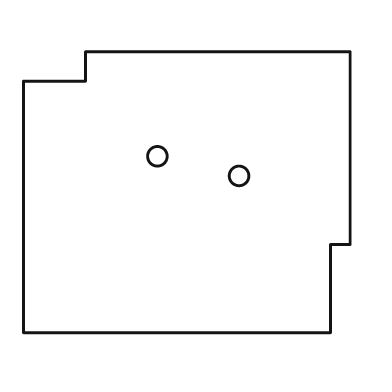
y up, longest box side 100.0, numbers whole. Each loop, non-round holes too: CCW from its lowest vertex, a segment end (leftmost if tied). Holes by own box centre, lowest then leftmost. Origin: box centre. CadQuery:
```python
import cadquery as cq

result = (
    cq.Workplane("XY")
    .moveTo(-50.0, -43.0)
    .lineTo(44.0, -43.0)
    .lineTo(44.0, -16.0)
    .lineTo(50.0, -16.0)
    .lineTo(50.0, 43.0)
    .lineTo(-31.0, 43.0)
    .lineTo(-31.0, 34.0)
    .lineTo(-50.0, 34.0)
    .close()
    .moveTo(16.0, 5.0)
    .circle(3.0)
    .moveTo(-9.0, 11.0)
    .circle(3.0)
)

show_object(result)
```